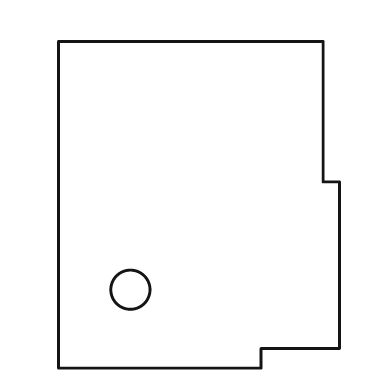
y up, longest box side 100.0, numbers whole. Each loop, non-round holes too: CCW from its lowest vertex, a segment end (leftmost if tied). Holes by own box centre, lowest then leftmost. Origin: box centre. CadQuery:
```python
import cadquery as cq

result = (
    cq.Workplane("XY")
    .moveTo(-43.0, -50.0)
    .lineTo(19.0, -50.0)
    .lineTo(19.0, -44.0)
    .lineTo(43.0, -44.0)
    .lineTo(43.0, 7.0)
    .lineTo(38.0, 7.0)
    .lineTo(38.0, 50.0)
    .lineTo(-43.0, 50.0)
    .close()
    .moveTo(-21.0, -26.0)
    .circle(6.0)
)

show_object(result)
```